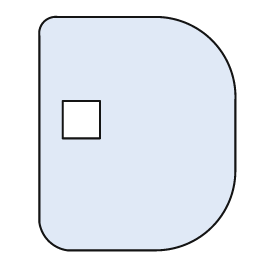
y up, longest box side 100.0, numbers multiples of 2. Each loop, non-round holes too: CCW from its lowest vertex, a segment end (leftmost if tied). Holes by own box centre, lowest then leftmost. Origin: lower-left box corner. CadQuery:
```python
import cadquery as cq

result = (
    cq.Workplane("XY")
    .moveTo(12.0, 0.0)
    .lineTo(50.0, 0.0)
    .threePointArc((74.0, 10.0), (84.0, 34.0))
    .lineTo(84.0, 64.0)
    .threePointArc((74.0, 90.0), (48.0, 100.0))
    .lineTo(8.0, 100.0)
    .threePointArc((2.0, 98.0), (0.0, 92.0))
    .lineTo(0.0, 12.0)
    .threePointArc((4.0, 4.0), (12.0, 0.0))
    .close()
    .moveTo(10.0, 48.0)
    .lineTo(26.0, 48.0)
    .lineTo(26.0, 64.0)
    .lineTo(10.0, 64.0)
    .close()
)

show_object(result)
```